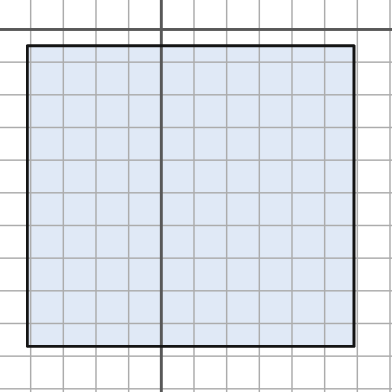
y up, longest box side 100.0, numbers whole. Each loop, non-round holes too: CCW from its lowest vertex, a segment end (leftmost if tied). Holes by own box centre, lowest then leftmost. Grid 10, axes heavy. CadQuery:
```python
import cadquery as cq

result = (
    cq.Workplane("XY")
    .moveTo(-41.0, -97.0)
    .lineTo(59.0, -97.0)
    .lineTo(59.0, -5.0)
    .lineTo(-41.0, -5.0)
    .close()
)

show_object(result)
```